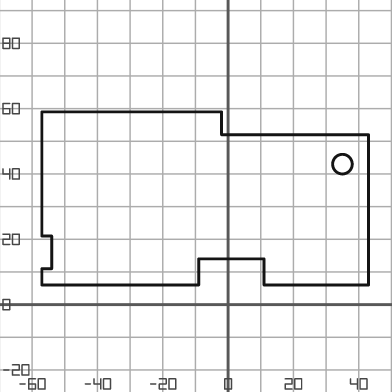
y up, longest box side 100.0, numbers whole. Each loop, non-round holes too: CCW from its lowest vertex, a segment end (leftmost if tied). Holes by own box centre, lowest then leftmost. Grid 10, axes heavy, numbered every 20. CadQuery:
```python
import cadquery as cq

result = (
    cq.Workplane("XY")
    .moveTo(-57.0, 6.0)
    .lineTo(-9.0, 6.0)
    .lineTo(-9.0, 14.0)
    .lineTo(11.0, 14.0)
    .lineTo(11.0, 6.0)
    .lineTo(43.0, 6.0)
    .lineTo(43.0, 52.0)
    .lineTo(-2.0, 52.0)
    .lineTo(-2.0, 59.0)
    .lineTo(-57.0, 59.0)
    .lineTo(-57.0, 21.0)
    .lineTo(-54.0, 21.0)
    .lineTo(-54.0, 11.0)
    .lineTo(-57.0, 11.0)
    .close()
    .moveTo(35.0, 43.0)
    .circle(3.0)
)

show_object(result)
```